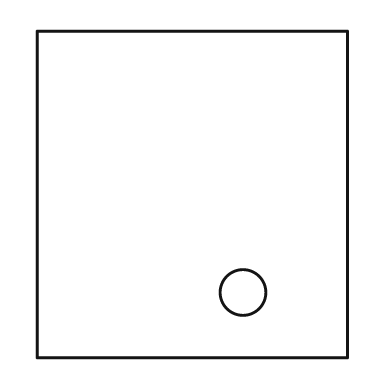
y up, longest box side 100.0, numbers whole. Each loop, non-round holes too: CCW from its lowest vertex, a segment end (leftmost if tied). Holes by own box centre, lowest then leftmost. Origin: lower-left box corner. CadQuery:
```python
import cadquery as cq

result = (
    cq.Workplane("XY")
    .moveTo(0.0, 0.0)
    .lineTo(95.0, 0.0)
    .lineTo(95.0, 100.0)
    .lineTo(0.0, 100.0)
    .close()
    .moveTo(63.0, 20.0)
    .circle(7.0)
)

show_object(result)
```